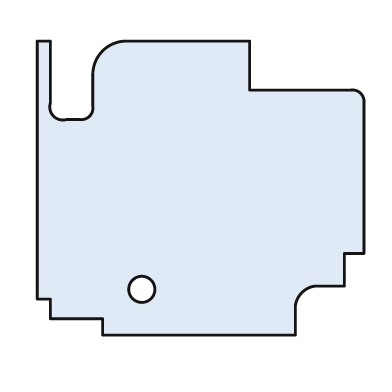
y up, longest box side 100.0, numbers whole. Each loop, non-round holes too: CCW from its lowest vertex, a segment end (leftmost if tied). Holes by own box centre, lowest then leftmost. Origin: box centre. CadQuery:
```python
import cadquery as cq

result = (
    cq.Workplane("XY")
    .moveTo(-30.0, -45.0)
    .lineTo(29.0, -45.0)
    .lineTo(29.0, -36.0)
    .threePointArc((31.0, -32.0), (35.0, -30.0))
    .lineTo(44.0, -30.0)
    .lineTo(44.0, -20.0)
    .lineTo(50.0, -20.0)
    .lineTo(50.0, 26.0)
    .threePointArc((49.0, 29.0), (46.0, 30.0))
    .lineTo(15.0, 30.0)
    .lineTo(15.0, 45.0)
    .lineTo(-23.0, 45.0)
    .threePointArc((-30.0, 42.0), (-33.0, 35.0))
    .lineTo(-33.0, 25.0)
    .threePointArc((-34.0, 22.0), (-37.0, 21.0))
    .lineTo(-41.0, 21.0)
    .threePointArc((-45.0, 22.0), (-46.0, 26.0))
    .lineTo(-46.0, 45.0)
    .lineTo(-50.0, 45.0)
    .lineTo(-50.0, -34.0)
    .lineTo(-46.0, -34.0)
    .lineTo(-46.0, -40.0)
    .lineTo(-30.0, -40.0)
    .close()
    .moveTo(-18.0, -31.0)
    .circle(4.0)
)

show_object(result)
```